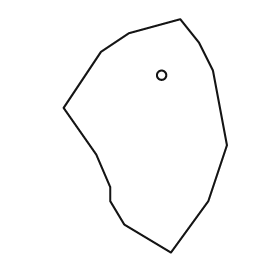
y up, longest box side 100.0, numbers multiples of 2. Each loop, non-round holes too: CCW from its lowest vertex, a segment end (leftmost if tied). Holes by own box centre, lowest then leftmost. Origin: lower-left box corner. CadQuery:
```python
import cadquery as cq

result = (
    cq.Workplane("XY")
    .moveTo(46.0, 0.0)
    .lineTo(62.0, 22.0)
    .lineTo(70.0, 46.0)
    .lineTo(64.0, 78.0)
    .lineTo(58.0, 90.0)
    .lineTo(50.0, 100.0)
    .lineTo(28.0, 94.0)
    .lineTo(16.0, 86.0)
    .lineTo(0.0, 62.0)
    .lineTo(14.0, 42.0)
    .lineTo(20.0, 28.0)
    .lineTo(20.0, 22.0)
    .lineTo(26.0, 12.0)
    .close()
    .moveTo(42.0, 76.0)
    .circle(2.0)
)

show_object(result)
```